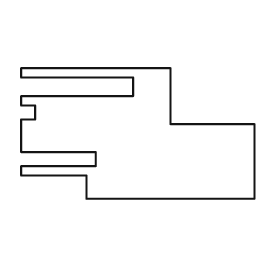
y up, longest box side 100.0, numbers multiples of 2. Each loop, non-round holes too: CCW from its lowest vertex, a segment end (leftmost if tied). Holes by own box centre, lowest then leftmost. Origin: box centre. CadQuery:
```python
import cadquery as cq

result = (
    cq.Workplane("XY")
    .moveTo(-22.0, -28.0)
    .lineTo(50.0, -28.0)
    .lineTo(50.0, 4.0)
    .lineTo(14.0, 4.0)
    .lineTo(14.0, 28.0)
    .lineTo(-50.0, 28.0)
    .lineTo(-50.0, 24.0)
    .lineTo(-2.0, 24.0)
    .lineTo(-2.0, 16.0)
    .lineTo(-50.0, 16.0)
    .lineTo(-50.0, 12.0)
    .lineTo(-44.0, 12.0)
    .lineTo(-44.0, 6.0)
    .lineTo(-50.0, 6.0)
    .lineTo(-50.0, -8.0)
    .lineTo(-18.0, -8.0)
    .lineTo(-18.0, -14.0)
    .lineTo(-50.0, -14.0)
    .lineTo(-50.0, -18.0)
    .lineTo(-22.0, -18.0)
    .close()
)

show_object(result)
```